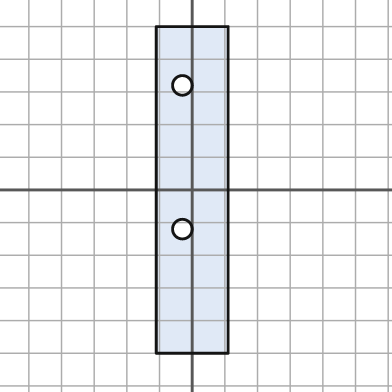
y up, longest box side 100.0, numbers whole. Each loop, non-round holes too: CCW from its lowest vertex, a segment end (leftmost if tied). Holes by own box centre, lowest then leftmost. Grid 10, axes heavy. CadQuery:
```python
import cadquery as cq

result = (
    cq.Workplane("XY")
    .moveTo(-11.0, -50.0)
    .lineTo(11.0, -50.0)
    .lineTo(11.0, 50.0)
    .lineTo(-11.0, 50.0)
    .close()
    .moveTo(-3.0, -12.0)
    .circle(3.0)
    .moveTo(-3.0, 32.0)
    .circle(3.0)
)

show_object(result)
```